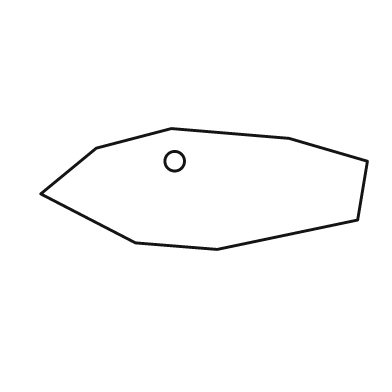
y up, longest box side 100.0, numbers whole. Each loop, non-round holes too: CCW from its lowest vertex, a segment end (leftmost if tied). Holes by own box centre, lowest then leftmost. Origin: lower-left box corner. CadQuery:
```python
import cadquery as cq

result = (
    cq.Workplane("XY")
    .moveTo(54.0, 0.0)
    .lineTo(97.0, 9.0)
    .lineTo(100.0, 27.0)
    .lineTo(76.0, 34.0)
    .lineTo(40.0, 37.0)
    .lineTo(17.0, 31.0)
    .lineTo(0.0, 17.0)
    .lineTo(29.0, 2.0)
    .close()
    .moveTo(41.0, 27.0)
    .circle(3.0)
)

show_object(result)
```